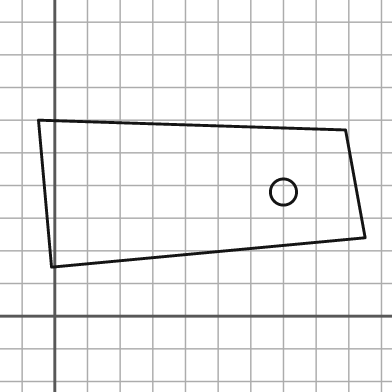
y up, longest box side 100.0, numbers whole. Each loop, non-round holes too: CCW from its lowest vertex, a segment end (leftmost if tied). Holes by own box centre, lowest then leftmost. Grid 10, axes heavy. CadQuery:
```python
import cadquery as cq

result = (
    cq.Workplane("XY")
    .moveTo(-1.0, 15.0)
    .lineTo(95.0, 24.0)
    .lineTo(89.0, 57.0)
    .lineTo(-5.0, 60.0)
    .close()
    .moveTo(70.0, 38.0)
    .circle(4.0)
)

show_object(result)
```